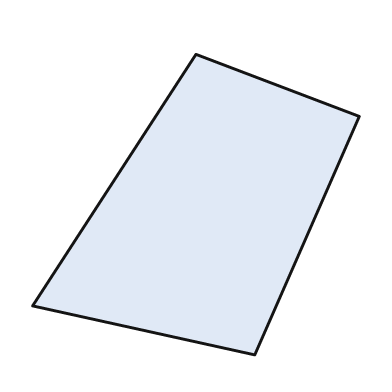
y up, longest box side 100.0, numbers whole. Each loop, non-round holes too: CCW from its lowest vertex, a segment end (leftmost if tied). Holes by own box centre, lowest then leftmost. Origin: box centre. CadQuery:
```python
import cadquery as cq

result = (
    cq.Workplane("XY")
    .moveTo(18.0, -46.0)
    .lineTo(50.0, 27.0)
    .lineTo(0.0, 46.0)
    .lineTo(-50.0, -31.0)
    .close()
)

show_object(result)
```